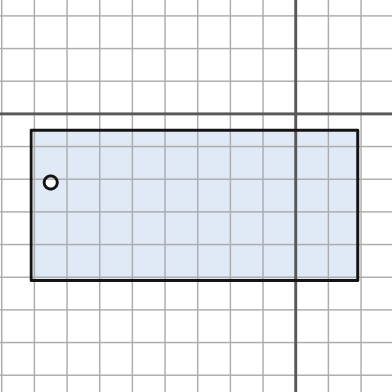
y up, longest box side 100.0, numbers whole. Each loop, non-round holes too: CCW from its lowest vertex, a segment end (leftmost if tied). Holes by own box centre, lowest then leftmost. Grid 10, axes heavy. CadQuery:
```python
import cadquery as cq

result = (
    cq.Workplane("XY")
    .moveTo(-81.0, -51.0)
    .lineTo(19.0, -51.0)
    .lineTo(19.0, -5.0)
    .lineTo(-81.0, -5.0)
    .close()
    .moveTo(-75.0, -21.0)
    .circle(2.0)
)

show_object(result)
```